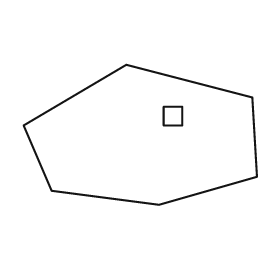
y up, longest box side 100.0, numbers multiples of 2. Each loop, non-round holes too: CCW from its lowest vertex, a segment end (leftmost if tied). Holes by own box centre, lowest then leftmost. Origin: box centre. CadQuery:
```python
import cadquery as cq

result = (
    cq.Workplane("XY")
    .moveTo(8.0, -30.0)
    .lineTo(50.0, -18.0)
    .lineTo(48.0, 16.0)
    .lineTo(-6.0, 30.0)
    .lineTo(-50.0, 4.0)
    .lineTo(-38.0, -24.0)
    .close()
    .moveTo(10.0, 4.0)
    .lineTo(18.0, 4.0)
    .lineTo(18.0, 12.0)
    .lineTo(10.0, 12.0)
    .close()
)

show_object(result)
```